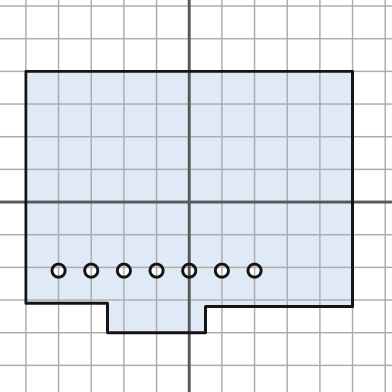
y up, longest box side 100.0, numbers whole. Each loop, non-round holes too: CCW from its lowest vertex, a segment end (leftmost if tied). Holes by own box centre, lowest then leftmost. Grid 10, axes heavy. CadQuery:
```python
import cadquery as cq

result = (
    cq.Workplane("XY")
    .moveTo(-25.0, -40.0)
    .lineTo(5.0, -40.0)
    .lineTo(5.0, -32.0)
    .lineTo(50.0, -32.0)
    .lineTo(50.0, 40.0)
    .lineTo(-50.0, 40.0)
    .lineTo(-50.0, -31.0)
    .lineTo(-25.0, -31.0)
    .close()
    .moveTo(-40.0, -21.0)
    .circle(2.0)
    .moveTo(-30.0, -21.0)
    .circle(2.0)
    .moveTo(-20.0, -21.0)
    .circle(2.0)
    .moveTo(-10.0, -21.0)
    .circle(2.0)
    .moveTo(0.0, -21.0)
    .circle(2.0)
    .moveTo(10.0, -21.0)
    .circle(2.0)
    .moveTo(20.0, -21.0)
    .circle(2.0)
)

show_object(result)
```